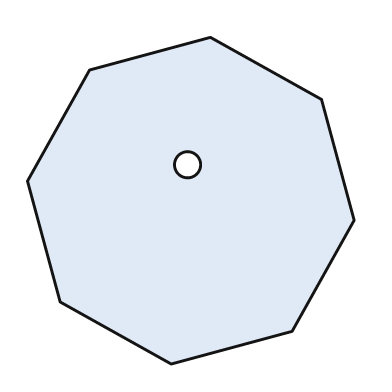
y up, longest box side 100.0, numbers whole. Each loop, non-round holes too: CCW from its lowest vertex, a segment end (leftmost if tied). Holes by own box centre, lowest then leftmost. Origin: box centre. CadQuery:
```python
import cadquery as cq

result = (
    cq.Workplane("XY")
    .moveTo(-6.0, -50.0)
    .lineTo(31.0, -40.0)
    .lineTo(50.0, -6.0)
    .lineTo(40.0, 31.0)
    .lineTo(6.0, 50.0)
    .lineTo(-31.0, 40.0)
    .lineTo(-50.0, 6.0)
    .lineTo(-40.0, -31.0)
    .close()
    .moveTo(-1.0, 11.0)
    .circle(4.0)
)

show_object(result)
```